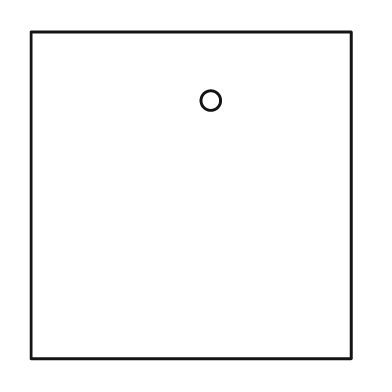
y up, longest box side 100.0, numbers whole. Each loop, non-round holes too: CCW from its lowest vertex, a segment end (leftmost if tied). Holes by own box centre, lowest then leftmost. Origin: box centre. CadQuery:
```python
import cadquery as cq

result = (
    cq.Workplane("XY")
    .moveTo(-49.0, -50.0)
    .lineTo(49.0, -50.0)
    .lineTo(49.0, 50.0)
    .lineTo(-49.0, 50.0)
    .close()
    .moveTo(6.0, 29.0)
    .circle(3.0)
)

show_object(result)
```